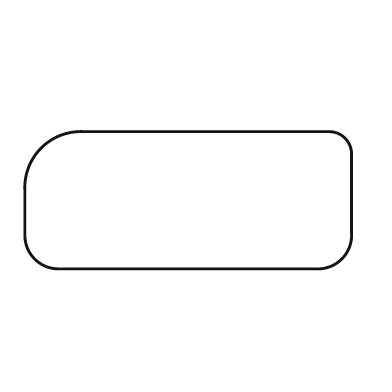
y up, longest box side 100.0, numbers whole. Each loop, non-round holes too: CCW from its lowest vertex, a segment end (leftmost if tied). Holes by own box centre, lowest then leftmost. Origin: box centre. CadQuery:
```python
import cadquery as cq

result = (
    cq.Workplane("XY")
    .moveTo(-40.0, -21.0)
    .lineTo(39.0, -21.0)
    .threePointArc((47.0, -18.0), (50.0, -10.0))
    .lineTo(50.0, 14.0)
    .threePointArc((48.0, 19.0), (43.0, 21.0))
    .lineTo(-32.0, 21.0)
    .threePointArc((-45.0, 16.0), (-50.0, 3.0))
    .lineTo(-50.0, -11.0)
    .threePointArc((-47.0, -18.0), (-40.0, -21.0))
    .close()
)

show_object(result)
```